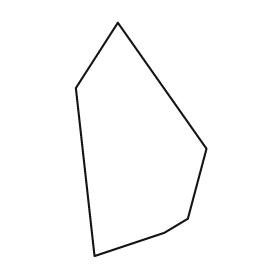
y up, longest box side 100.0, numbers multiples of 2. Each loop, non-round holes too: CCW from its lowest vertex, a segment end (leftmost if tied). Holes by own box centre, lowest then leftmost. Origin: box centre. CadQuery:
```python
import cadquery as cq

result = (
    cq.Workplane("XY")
    .moveTo(-20.0, -50.0)
    .lineTo(10.0, -40.0)
    .lineTo(20.0, -34.0)
    .lineTo(28.0, -4.0)
    .lineTo(-10.0, 50.0)
    .lineTo(-28.0, 22.0)
    .close()
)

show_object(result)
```